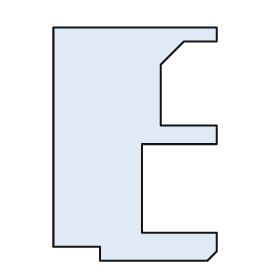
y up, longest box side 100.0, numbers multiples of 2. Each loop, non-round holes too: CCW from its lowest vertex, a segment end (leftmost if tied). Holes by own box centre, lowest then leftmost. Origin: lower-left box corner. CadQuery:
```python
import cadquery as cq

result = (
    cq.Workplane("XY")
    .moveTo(20.0, 0.0)
    .lineTo(66.0, 0.0)
    .lineTo(70.0, 4.0)
    .lineTo(70.0, 12.0)
    .lineTo(38.0, 12.0)
    .lineTo(38.0, 50.0)
    .lineTo(70.0, 50.0)
    .lineTo(70.0, 58.0)
    .lineTo(46.0, 58.0)
    .lineTo(46.0, 84.0)
    .lineTo(56.0, 94.0)
    .lineTo(70.0, 94.0)
    .lineTo(70.0, 100.0)
    .lineTo(0.0, 100.0)
    .lineTo(0.0, 6.0)
    .lineTo(20.0, 6.0)
    .close()
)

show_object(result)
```